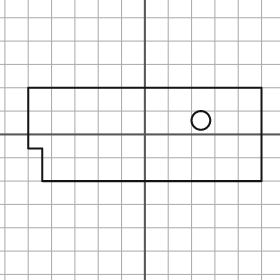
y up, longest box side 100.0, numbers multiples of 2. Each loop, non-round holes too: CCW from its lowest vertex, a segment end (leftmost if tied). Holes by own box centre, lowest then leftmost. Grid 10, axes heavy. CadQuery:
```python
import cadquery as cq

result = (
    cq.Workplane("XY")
    .moveTo(-44.0, -20.0)
    .lineTo(50.0, -20.0)
    .lineTo(50.0, 20.0)
    .lineTo(-50.0, 20.0)
    .lineTo(-50.0, -6.0)
    .lineTo(-44.0, -6.0)
    .close()
    .moveTo(24.0, 6.0)
    .circle(4.0)
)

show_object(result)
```